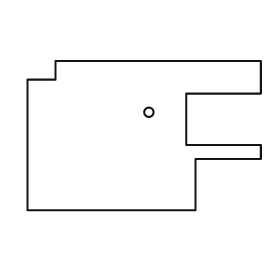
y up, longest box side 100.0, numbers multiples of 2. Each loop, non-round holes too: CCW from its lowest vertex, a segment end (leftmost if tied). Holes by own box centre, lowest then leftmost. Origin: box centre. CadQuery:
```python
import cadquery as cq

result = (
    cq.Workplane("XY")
    .moveTo(-50.0, -32.0)
    .lineTo(22.0, -32.0)
    .lineTo(22.0, -10.0)
    .lineTo(50.0, -10.0)
    .lineTo(50.0, -4.0)
    .lineTo(18.0, -4.0)
    .lineTo(18.0, 18.0)
    .lineTo(50.0, 18.0)
    .lineTo(50.0, 32.0)
    .lineTo(-38.0, 32.0)
    .lineTo(-38.0, 24.0)
    .lineTo(-50.0, 24.0)
    .close()
    .moveTo(2.0, 10.0)
    .circle(2.0)
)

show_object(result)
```